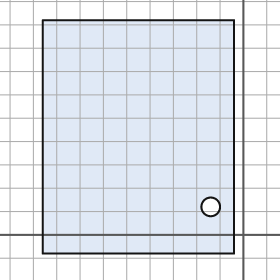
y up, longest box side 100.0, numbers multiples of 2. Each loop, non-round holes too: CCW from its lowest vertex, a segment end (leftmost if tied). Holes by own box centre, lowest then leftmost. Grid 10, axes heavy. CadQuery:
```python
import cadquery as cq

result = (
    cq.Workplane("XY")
    .moveTo(-86.0, -8.0)
    .lineTo(-4.0, -8.0)
    .lineTo(-4.0, 92.0)
    .lineTo(-86.0, 92.0)
    .close()
    .moveTo(-14.0, 12.0)
    .circle(4.0)
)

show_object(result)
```